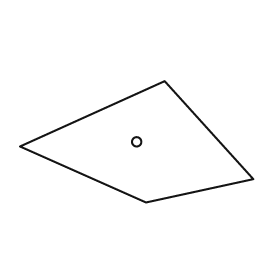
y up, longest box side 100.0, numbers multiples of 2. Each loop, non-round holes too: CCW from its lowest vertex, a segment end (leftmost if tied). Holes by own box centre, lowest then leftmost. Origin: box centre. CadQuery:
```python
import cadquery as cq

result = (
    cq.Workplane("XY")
    .moveTo(4.0, -26.0)
    .lineTo(50.0, -16.0)
    .lineTo(12.0, 26.0)
    .lineTo(-50.0, -2.0)
    .close()
    .moveTo(0.0, 0.0)
    .circle(2.0)
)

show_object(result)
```